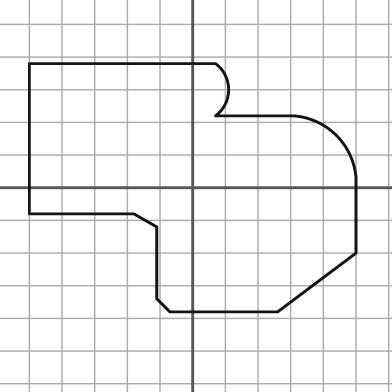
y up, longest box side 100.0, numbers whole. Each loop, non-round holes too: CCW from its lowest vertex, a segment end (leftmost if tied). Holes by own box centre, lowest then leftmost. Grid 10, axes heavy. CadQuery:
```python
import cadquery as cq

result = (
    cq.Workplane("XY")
    .moveTo(-7.0, -38.0)
    .lineTo(26.0, -38.0)
    .lineTo(50.0, -20.0)
    .lineTo(50.0, 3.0)
    .threePointArc((44.0, 16.0), (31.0, 22.0))
    .lineTo(7.0, 22.0)
    .threePointArc((11.0, 30.0), (7.0, 38.0))
    .lineTo(-50.0, 38.0)
    .lineTo(-50.0, -8.0)
    .lineTo(-18.0, -8.0)
    .lineTo(-11.0, -12.0)
    .lineTo(-11.0, -34.0)
    .close()
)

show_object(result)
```